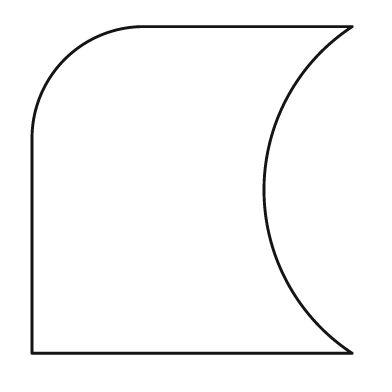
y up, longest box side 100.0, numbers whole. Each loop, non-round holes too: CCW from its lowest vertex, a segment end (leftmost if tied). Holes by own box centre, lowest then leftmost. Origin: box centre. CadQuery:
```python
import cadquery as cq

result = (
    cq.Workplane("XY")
    .moveTo(-49.0, -50.0)
    .lineTo(49.0, -50.0)
    .threePointArc((22.0, 0.0), (49.0, 50.0))
    .lineTo(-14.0, 50.0)
    .threePointArc((-39.0, 40.0), (-49.0, 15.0))
    .close()
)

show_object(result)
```